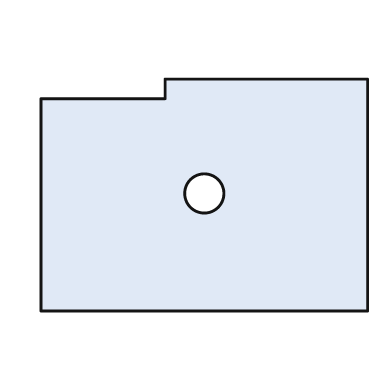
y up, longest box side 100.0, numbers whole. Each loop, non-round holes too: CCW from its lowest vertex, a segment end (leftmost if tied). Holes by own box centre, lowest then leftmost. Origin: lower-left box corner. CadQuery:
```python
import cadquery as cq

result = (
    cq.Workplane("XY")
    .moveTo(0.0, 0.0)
    .lineTo(100.0, 0.0)
    .lineTo(100.0, 71.0)
    .lineTo(38.0, 71.0)
    .lineTo(38.0, 65.0)
    .lineTo(0.0, 65.0)
    .close()
    .moveTo(50.0, 36.0)
    .circle(6.0)
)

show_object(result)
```